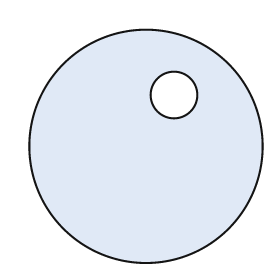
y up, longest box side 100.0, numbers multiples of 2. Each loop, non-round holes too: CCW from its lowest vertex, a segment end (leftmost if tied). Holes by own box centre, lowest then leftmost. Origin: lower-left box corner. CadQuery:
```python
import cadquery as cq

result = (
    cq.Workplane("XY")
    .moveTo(50.0, 50.0)
    .circle(50.0)
    .moveTo(62.0, 72.0)
    .circle(10.0)
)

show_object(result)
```